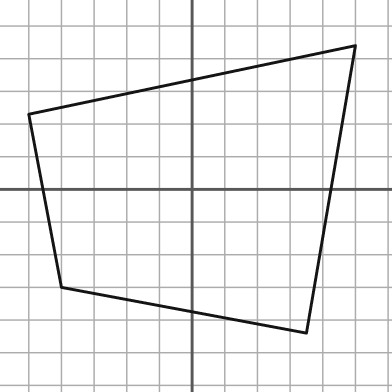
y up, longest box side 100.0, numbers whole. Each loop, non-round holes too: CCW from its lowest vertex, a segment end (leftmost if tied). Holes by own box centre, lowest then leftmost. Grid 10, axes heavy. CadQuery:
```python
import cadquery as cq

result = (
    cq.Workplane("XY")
    .moveTo(35.0, -44.0)
    .lineTo(50.0, 44.0)
    .lineTo(-50.0, 23.0)
    .lineTo(-40.0, -30.0)
    .close()
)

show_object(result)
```